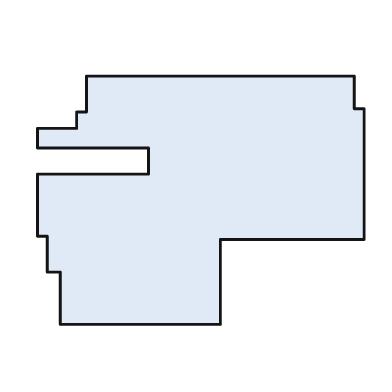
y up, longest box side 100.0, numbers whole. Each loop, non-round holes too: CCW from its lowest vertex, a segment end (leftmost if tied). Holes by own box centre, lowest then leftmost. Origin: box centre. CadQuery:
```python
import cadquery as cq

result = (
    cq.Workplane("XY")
    .moveTo(-43.0, -38.0)
    .lineTo(6.0, -38.0)
    .lineTo(6.0, -12.0)
    .lineTo(50.0, -12.0)
    .lineTo(50.0, 28.0)
    .lineTo(47.0, 28.0)
    .lineTo(47.0, 38.0)
    .lineTo(-35.0, 38.0)
    .lineTo(-35.0, 27.0)
    .lineTo(-38.0, 27.0)
    .lineTo(-38.0, 22.0)
    .lineTo(-50.0, 22.0)
    .lineTo(-50.0, 16.0)
    .lineTo(-16.0, 16.0)
    .lineTo(-16.0, 8.0)
    .lineTo(-50.0, 8.0)
    .lineTo(-50.0, -11.0)
    .lineTo(-47.0, -11.0)
    .lineTo(-47.0, -22.0)
    .lineTo(-43.0, -22.0)
    .close()
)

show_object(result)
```